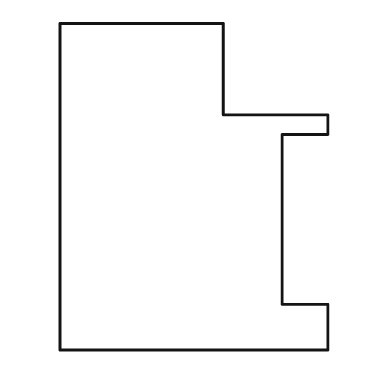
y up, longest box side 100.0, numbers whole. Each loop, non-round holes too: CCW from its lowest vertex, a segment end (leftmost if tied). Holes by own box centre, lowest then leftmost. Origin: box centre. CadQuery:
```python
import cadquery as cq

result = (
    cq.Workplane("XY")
    .moveTo(-41.0, -50.0)
    .lineTo(41.0, -50.0)
    .lineTo(41.0, -36.0)
    .lineTo(27.0, -36.0)
    .lineTo(27.0, 16.0)
    .lineTo(41.0, 16.0)
    .lineTo(41.0, 22.0)
    .lineTo(9.0, 22.0)
    .lineTo(9.0, 50.0)
    .lineTo(-41.0, 50.0)
    .close()
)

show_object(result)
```